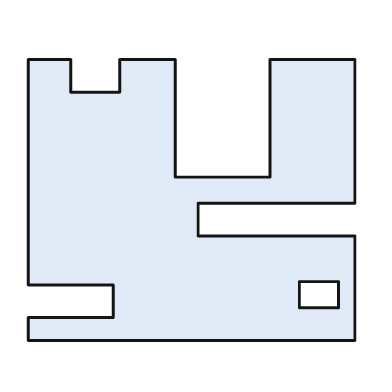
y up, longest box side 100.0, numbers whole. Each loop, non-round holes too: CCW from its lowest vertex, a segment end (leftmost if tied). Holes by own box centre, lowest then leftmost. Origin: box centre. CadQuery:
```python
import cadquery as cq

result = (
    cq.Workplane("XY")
    .moveTo(-50.0, -43.0)
    .lineTo(50.0, -43.0)
    .lineTo(50.0, -11.0)
    .lineTo(2.0, -11.0)
    .lineTo(2.0, -1.0)
    .lineTo(50.0, -1.0)
    .lineTo(50.0, 43.0)
    .lineTo(24.0, 43.0)
    .lineTo(24.0, 7.0)
    .lineTo(-5.0, 7.0)
    .lineTo(-5.0, 43.0)
    .lineTo(-22.0, 43.0)
    .lineTo(-22.0, 33.0)
    .lineTo(-37.0, 33.0)
    .lineTo(-37.0, 43.0)
    .lineTo(-50.0, 43.0)
    .lineTo(-50.0, -26.0)
    .lineTo(-24.0, -26.0)
    .lineTo(-24.0, -36.0)
    .lineTo(-50.0, -36.0)
    .close()
    .moveTo(33.0, -33.0)
    .lineTo(45.0, -33.0)
    .lineTo(45.0, -25.0)
    .lineTo(33.0, -25.0)
    .close()
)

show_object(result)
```